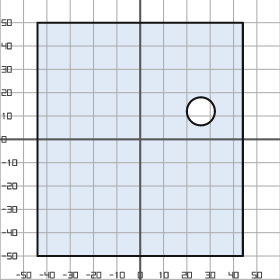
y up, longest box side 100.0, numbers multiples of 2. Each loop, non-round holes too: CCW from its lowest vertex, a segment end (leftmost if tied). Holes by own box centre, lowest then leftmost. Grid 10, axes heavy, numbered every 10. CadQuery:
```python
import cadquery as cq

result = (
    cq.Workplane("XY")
    .moveTo(-44.0, -50.0)
    .lineTo(44.0, -50.0)
    .lineTo(44.0, 50.0)
    .lineTo(-44.0, 50.0)
    .close()
    .moveTo(26.0, 12.0)
    .circle(6.0)
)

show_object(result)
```